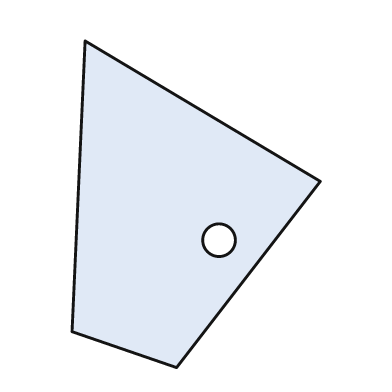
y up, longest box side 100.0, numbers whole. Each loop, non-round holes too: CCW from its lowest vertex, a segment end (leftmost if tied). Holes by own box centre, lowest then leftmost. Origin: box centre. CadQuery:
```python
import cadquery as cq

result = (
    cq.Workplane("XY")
    .moveTo(-6.0, -50.0)
    .lineTo(38.0, 7.0)
    .lineTo(-34.0, 50.0)
    .lineTo(-38.0, -39.0)
    .close()
    .moveTo(7.0, -11.0)
    .circle(5.0)
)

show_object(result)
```